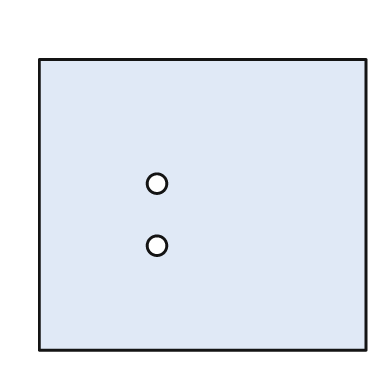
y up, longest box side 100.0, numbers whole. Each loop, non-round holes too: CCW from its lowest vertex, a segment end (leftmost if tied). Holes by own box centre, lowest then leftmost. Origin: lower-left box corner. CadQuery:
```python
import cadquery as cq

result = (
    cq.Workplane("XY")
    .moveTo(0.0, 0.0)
    .lineTo(100.0, 0.0)
    .lineTo(100.0, 89.0)
    .lineTo(0.0, 89.0)
    .close()
    .moveTo(36.0, 32.0)
    .circle(3.0)
    .moveTo(36.0, 51.0)
    .circle(3.0)
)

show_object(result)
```